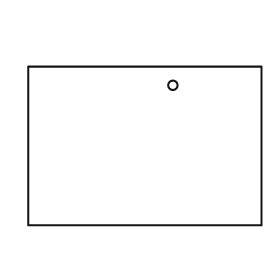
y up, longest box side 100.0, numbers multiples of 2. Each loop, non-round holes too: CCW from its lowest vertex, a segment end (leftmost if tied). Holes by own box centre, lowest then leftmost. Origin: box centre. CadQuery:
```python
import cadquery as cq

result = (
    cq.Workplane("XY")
    .moveTo(-50.0, -34.0)
    .lineTo(50.0, -34.0)
    .lineTo(50.0, 34.0)
    .lineTo(-50.0, 34.0)
    .close()
    .moveTo(12.0, 26.0)
    .circle(2.0)
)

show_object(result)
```